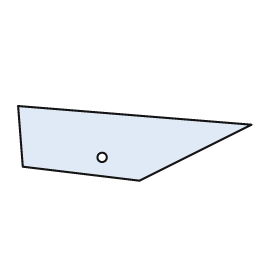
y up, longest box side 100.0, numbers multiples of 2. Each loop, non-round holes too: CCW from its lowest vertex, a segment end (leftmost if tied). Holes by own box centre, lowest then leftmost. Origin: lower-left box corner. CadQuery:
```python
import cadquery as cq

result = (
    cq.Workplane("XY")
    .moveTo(52.0, 0.0)
    .lineTo(100.0, 24.0)
    .lineTo(0.0, 32.0)
    .lineTo(2.0, 6.0)
    .close()
    .moveTo(36.0, 10.0)
    .circle(2.0)
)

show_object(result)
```